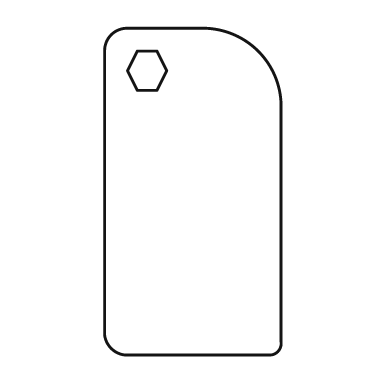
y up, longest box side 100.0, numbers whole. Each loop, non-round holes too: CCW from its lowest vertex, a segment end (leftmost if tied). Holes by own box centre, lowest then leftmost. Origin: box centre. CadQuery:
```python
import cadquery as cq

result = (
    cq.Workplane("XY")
    .moveTo(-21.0, -50.0)
    .lineTo(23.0, -50.0)
    .threePointArc((26.0, -49.0), (27.0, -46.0))
    .lineTo(27.0, 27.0)
    .threePointArc((20.0, 43.0), (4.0, 50.0))
    .lineTo(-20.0, 50.0)
    .threePointArc((-25.0, 48.0), (-27.0, 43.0))
    .lineTo(-27.0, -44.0)
    .threePointArc((-25.0, -48.0), (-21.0, -50.0))
    .close()
    .moveTo(-17.0, 31.0)
    .lineTo(-11.0, 31.0)
    .lineTo(-8.0, 37.0)
    .lineTo(-11.0, 43.0)
    .lineTo(-17.0, 43.0)
    .lineTo(-20.0, 37.0)
    .close()
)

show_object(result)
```